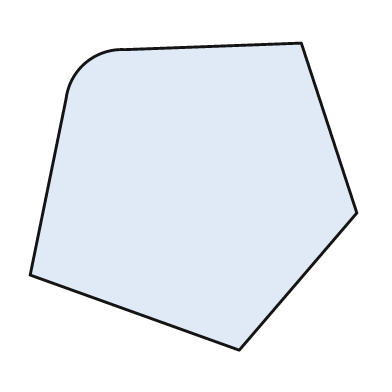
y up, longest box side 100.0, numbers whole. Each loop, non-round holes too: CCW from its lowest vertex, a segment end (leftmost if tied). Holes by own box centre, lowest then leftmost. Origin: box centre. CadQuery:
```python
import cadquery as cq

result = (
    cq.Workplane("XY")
    .moveTo(14.0, -47.0)
    .lineTo(50.0, -5.0)
    .lineTo(33.0, 47.0)
    .lineTo(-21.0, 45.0)
    .threePointArc((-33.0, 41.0), (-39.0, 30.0))
    .lineTo(-50.0, -24.0)
    .close()
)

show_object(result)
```